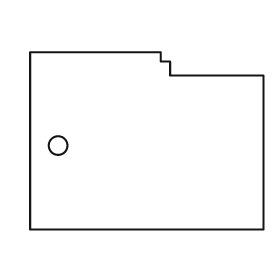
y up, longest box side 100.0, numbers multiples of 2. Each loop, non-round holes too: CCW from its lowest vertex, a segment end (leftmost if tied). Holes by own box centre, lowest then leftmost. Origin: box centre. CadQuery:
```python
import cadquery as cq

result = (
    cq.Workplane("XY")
    .moveTo(-50.0, -38.0)
    .lineTo(50.0, -38.0)
    .lineTo(50.0, 28.0)
    .lineTo(10.0, 28.0)
    .lineTo(10.0, 34.0)
    .lineTo(6.0, 34.0)
    .lineTo(6.0, 38.0)
    .lineTo(-50.0, 38.0)
    .close()
    .moveTo(-38.0, -2.0)
    .circle(4.0)
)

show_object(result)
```